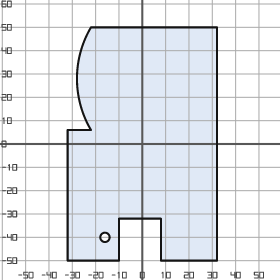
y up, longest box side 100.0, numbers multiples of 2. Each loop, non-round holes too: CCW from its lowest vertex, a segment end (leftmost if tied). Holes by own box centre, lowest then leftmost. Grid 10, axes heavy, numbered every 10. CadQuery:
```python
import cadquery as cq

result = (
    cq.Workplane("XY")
    .moveTo(-32.0, -50.0)
    .lineTo(-10.0, -50.0)
    .lineTo(-10.0, -32.0)
    .lineTo(8.0, -32.0)
    .lineTo(8.0, -50.0)
    .lineTo(32.0, -50.0)
    .lineTo(32.0, 50.0)
    .lineTo(-22.0, 50.0)
    .threePointArc((-28.0, 28.0), (-22.0, 6.0))
    .lineTo(-32.0, 6.0)
    .close()
    .moveTo(-16.0, -40.0)
    .circle(2.0)
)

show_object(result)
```